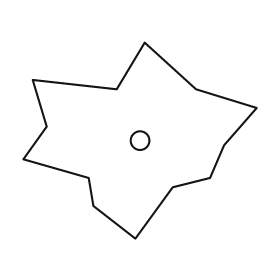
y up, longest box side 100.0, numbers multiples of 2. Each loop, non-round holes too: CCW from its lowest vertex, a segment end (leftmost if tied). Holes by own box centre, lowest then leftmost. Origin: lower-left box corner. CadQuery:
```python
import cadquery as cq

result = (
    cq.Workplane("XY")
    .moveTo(48.0, 0.0)
    .lineTo(64.0, 22.0)
    .lineTo(80.0, 26.0)
    .lineTo(86.0, 40.0)
    .lineTo(100.0, 56.0)
    .lineTo(74.0, 64.0)
    .lineTo(52.0, 84.0)
    .lineTo(40.0, 64.0)
    .lineTo(4.0, 68.0)
    .lineTo(10.0, 48.0)
    .lineTo(0.0, 34.0)
    .lineTo(28.0, 26.0)
    .lineTo(30.0, 14.0)
    .close()
    .moveTo(50.0, 42.0)
    .circle(4.0)
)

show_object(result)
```